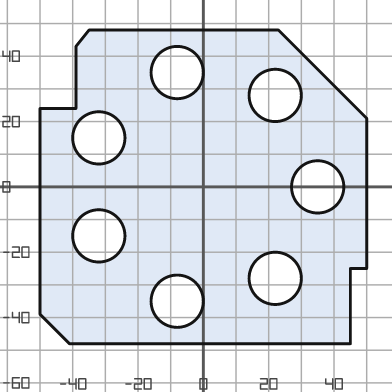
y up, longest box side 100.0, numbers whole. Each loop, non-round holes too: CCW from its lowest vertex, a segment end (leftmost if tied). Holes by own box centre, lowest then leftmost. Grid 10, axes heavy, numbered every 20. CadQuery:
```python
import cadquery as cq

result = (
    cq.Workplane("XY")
    .moveTo(-41.0, -48.0)
    .lineTo(45.0, -48.0)
    .lineTo(45.0, -25.0)
    .lineTo(50.0, -25.0)
    .lineTo(50.0, 21.0)
    .lineTo(23.0, 48.0)
    .lineTo(-35.0, 48.0)
    .lineTo(-39.0, 43.0)
    .lineTo(-39.0, 24.0)
    .lineTo(-50.0, 24.0)
    .lineTo(-50.0, -39.0)
    .close()
    .moveTo(-8.0, -35.0)
    .circle(8.0)
    .moveTo(22.0, -28.0)
    .circle(8.0)
    .moveTo(-32.0, -15.0)
    .circle(8.0)
    .moveTo(35.0, 0.0)
    .circle(8.0)
    .moveTo(-32.0, 15.0)
    .circle(8.0)
    .moveTo(22.0, 28.0)
    .circle(8.0)
    .moveTo(-8.0, 35.0)
    .circle(8.0)
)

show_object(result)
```